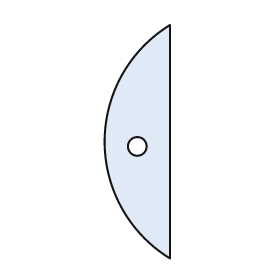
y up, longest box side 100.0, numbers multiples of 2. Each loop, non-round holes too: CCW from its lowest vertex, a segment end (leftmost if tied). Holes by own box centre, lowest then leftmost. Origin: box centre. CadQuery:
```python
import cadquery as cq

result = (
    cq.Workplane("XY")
    .moveTo(14.0, -50.0)
    .lineTo(14.0, 50.0)
    .threePointArc((-14.0, 0.0), (14.0, -50.0))
    .close()
    .moveTo(0.0, -2.0)
    .circle(4.0)
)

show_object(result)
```